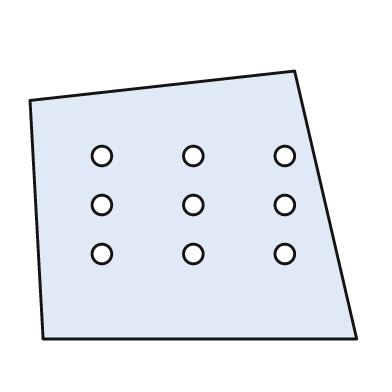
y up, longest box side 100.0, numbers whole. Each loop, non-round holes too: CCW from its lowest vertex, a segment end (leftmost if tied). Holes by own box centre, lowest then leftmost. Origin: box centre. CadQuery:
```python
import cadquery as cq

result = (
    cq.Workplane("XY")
    .moveTo(-46.0, -41.0)
    .lineTo(50.0, -41.0)
    .lineTo(31.0, 41.0)
    .lineTo(-50.0, 32.0)
    .close()
    .moveTo(-28.0, -15.0)
    .circle(3.0)
    .moveTo(0.0, -15.0)
    .circle(3.0)
    .moveTo(28.0, -15.0)
    .circle(3.0)
    .moveTo(-28.0, 0.0)
    .circle(3.0)
    .moveTo(0.0, 0.0)
    .circle(3.0)
    .moveTo(28.0, 0.0)
    .circle(3.0)
    .moveTo(-28.0, 15.0)
    .circle(3.0)
    .moveTo(0.0, 15.0)
    .circle(3.0)
    .moveTo(28.0, 15.0)
    .circle(3.0)
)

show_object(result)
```